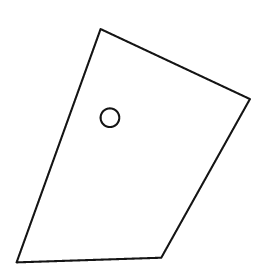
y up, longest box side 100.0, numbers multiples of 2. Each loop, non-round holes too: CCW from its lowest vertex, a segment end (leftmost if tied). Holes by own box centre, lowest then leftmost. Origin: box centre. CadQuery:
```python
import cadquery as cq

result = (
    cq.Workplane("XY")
    .moveTo(-50.0, -50.0)
    .lineTo(12.0, -48.0)
    .lineTo(50.0, 20.0)
    .lineTo(-14.0, 50.0)
    .close()
    .moveTo(-10.0, 12.0)
    .circle(4.0)
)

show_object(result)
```